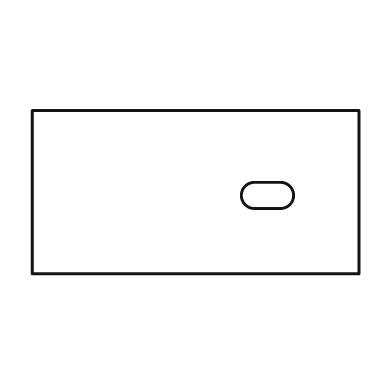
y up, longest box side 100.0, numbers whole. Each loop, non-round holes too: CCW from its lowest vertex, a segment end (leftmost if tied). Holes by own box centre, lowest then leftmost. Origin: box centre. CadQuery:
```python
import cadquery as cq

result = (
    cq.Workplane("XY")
    .moveTo(-50.0, -25.0)
    .lineTo(50.0, -25.0)
    .lineTo(50.0, 25.0)
    .lineTo(-50.0, 25.0)
    .close()
    .moveTo(18.0, -5.0)
    .lineTo(26.0, -5.0)
    .threePointArc((30.0, -1.0), (26.0, 3.0))
    .lineTo(18.0, 3.0)
    .threePointArc((14.0, -1.0), (18.0, -5.0))
    .close()
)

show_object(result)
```